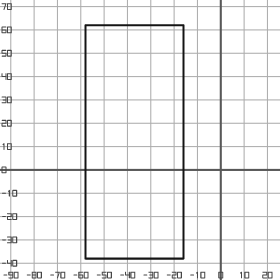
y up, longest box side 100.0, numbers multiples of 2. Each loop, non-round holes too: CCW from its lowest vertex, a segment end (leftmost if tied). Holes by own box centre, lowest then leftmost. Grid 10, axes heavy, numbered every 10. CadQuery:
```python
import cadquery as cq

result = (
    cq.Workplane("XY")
    .moveTo(-58.0, -38.0)
    .lineTo(-16.0, -38.0)
    .lineTo(-16.0, 62.0)
    .lineTo(-58.0, 62.0)
    .close()
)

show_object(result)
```